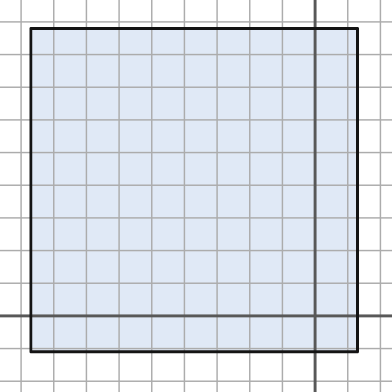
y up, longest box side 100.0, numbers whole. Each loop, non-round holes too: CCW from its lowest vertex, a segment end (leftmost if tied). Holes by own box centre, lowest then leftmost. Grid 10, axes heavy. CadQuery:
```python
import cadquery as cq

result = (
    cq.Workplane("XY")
    .moveTo(-87.0, -11.0)
    .lineTo(13.0, -11.0)
    .lineTo(13.0, 88.0)
    .lineTo(-87.0, 88.0)
    .close()
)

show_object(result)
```